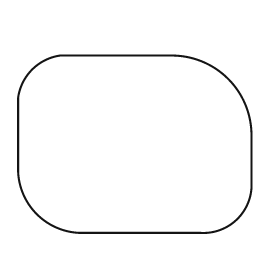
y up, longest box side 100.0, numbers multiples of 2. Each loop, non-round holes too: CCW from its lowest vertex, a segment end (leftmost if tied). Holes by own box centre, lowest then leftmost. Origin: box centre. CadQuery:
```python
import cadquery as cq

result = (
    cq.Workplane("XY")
    .moveTo(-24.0, -38.0)
    .lineTo(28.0, -38.0)
    .threePointArc((44.0, -32.0), (50.0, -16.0))
    .lineTo(50.0, 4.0)
    .threePointArc((40.0, 28.0), (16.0, 38.0))
    .lineTo(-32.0, 38.0)
    .threePointArc((-44.0, 32.0), (-50.0, 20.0))
    .lineTo(-50.0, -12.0)
    .threePointArc((-42.0, -30.0), (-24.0, -38.0))
    .close()
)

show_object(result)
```